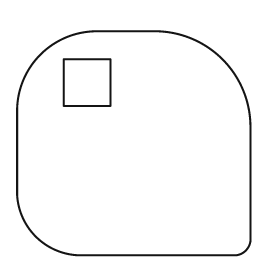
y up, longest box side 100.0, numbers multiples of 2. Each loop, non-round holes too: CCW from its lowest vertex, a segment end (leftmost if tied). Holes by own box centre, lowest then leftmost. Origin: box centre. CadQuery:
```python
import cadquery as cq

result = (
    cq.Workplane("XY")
    .moveTo(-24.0, -48.0)
    .lineTo(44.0, -48.0)
    .threePointArc((48.0, -46.0), (50.0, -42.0))
    .lineTo(50.0, 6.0)
    .threePointArc((38.0, 36.0), (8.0, 48.0))
    .lineTo(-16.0, 48.0)
    .threePointArc((-40.0, 38.0), (-50.0, 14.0))
    .lineTo(-50.0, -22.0)
    .threePointArc((-42.0, -40.0), (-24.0, -48.0))
    .close()
    .moveTo(-30.0, 16.0)
    .lineTo(-10.0, 16.0)
    .lineTo(-10.0, 36.0)
    .lineTo(-30.0, 36.0)
    .close()
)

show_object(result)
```